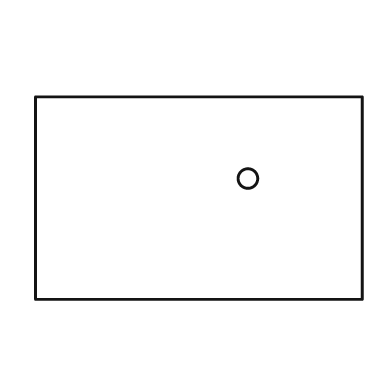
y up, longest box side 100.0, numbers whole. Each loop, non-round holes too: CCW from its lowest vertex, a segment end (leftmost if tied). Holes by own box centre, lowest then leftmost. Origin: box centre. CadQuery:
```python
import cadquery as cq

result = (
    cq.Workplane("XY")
    .moveTo(-50.0, -31.0)
    .lineTo(50.0, -31.0)
    .lineTo(50.0, 31.0)
    .lineTo(-50.0, 31.0)
    .close()
    .moveTo(15.0, 6.0)
    .circle(3.0)
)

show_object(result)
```